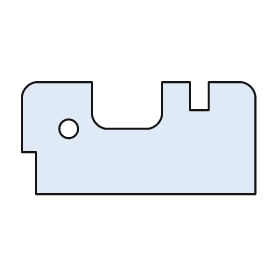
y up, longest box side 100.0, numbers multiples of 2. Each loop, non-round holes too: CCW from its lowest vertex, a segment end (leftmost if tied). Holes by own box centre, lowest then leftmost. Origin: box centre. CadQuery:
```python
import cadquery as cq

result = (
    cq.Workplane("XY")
    .moveTo(-44.0, -24.0)
    .lineTo(50.0, -24.0)
    .lineTo(50.0, 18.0)
    .threePointArc((48.0, 22.0), (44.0, 24.0))
    .lineTo(30.0, 24.0)
    .lineTo(30.0, 12.0)
    .lineTo(22.0, 12.0)
    .lineTo(22.0, 24.0)
    .lineTo(10.0, 24.0)
    .lineTo(10.0, 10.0)
    .threePointArc((8.0, 6.0), (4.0, 4.0))
    .lineTo(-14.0, 4.0)
    .threePointArc((-18.0, 6.0), (-20.0, 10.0))
    .lineTo(-20.0, 24.0)
    .lineTo(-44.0, 24.0)
    .threePointArc((-48.0, 22.0), (-50.0, 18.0))
    .lineTo(-50.0, -6.0)
    .lineTo(-44.0, -6.0)
    .close()
    .moveTo(-30.0, 4.0)
    .circle(4.0)
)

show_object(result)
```